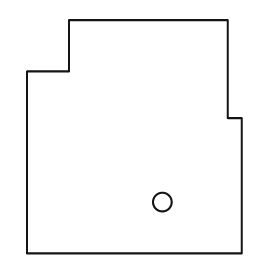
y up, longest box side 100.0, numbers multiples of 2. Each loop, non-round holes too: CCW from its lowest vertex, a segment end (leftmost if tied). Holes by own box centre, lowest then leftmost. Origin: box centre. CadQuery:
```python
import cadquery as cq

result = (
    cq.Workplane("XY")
    .moveTo(-46.0, -50.0)
    .lineTo(46.0, -50.0)
    .lineTo(46.0, 8.0)
    .lineTo(40.0, 8.0)
    .lineTo(40.0, 50.0)
    .lineTo(-28.0, 50.0)
    .lineTo(-28.0, 28.0)
    .lineTo(-46.0, 28.0)
    .close()
    .moveTo(12.0, -28.0)
    .circle(4.0)
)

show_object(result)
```